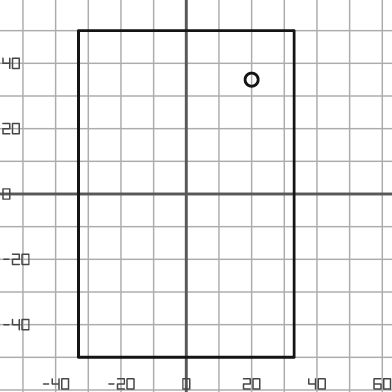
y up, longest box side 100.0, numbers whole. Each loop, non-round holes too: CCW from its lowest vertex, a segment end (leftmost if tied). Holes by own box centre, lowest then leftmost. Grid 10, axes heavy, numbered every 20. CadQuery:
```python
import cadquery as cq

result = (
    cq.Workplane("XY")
    .moveTo(-33.0, -50.0)
    .lineTo(33.0, -50.0)
    .lineTo(33.0, 50.0)
    .lineTo(-33.0, 50.0)
    .close()
    .moveTo(20.0, 35.0)
    .circle(2.0)
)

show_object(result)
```